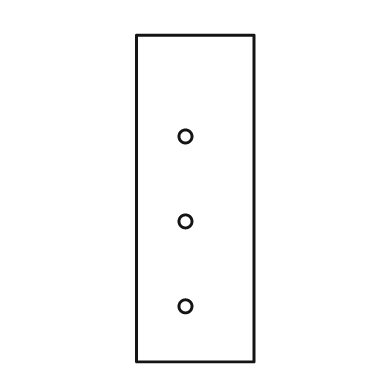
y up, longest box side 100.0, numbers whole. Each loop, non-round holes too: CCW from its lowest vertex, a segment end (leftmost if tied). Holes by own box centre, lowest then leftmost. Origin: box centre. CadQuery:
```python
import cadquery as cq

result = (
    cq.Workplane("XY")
    .moveTo(-18.0, -50.0)
    .lineTo(18.0, -50.0)
    .lineTo(18.0, 50.0)
    .lineTo(-18.0, 50.0)
    .close()
    .moveTo(-3.0, -33.0)
    .circle(2.0)
    .moveTo(-3.0, -7.0)
    .circle(2.0)
    .moveTo(-3.0, 19.0)
    .circle(2.0)
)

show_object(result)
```